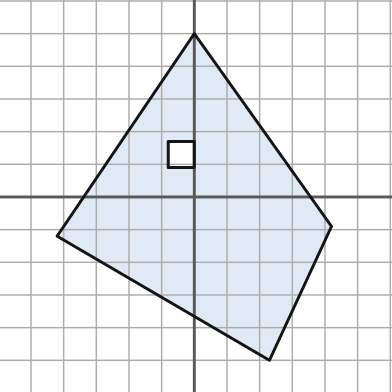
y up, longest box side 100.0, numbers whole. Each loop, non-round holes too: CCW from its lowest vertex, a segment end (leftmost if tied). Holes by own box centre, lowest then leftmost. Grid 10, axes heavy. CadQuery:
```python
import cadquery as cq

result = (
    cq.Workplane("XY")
    .moveTo(23.0, -50.0)
    .lineTo(42.0, -9.0)
    .lineTo(0.0, 50.0)
    .lineTo(-42.0, -12.0)
    .close()
    .moveTo(-8.0, 9.0)
    .lineTo(0.0, 9.0)
    .lineTo(0.0, 17.0)
    .lineTo(-8.0, 17.0)
    .close()
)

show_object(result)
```